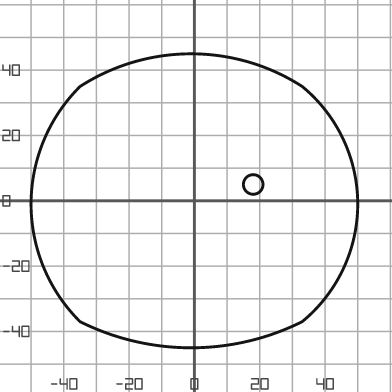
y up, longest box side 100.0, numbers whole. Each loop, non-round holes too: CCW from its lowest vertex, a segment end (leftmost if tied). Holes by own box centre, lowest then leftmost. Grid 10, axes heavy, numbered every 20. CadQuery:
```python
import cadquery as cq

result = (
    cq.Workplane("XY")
    .moveTo(-35.0, -37.0)
    .threePointArc((-1.0, -45.0), (33.0, -37.0))
    .threePointArc((50.0, -1.0), (33.0, 35.0))
    .threePointArc((-1.0, 45.0), (-35.0, 35.0))
    .threePointArc((-50.0, -1.0), (-35.0, -37.0))
    .close()
    .moveTo(18.0, 5.0)
    .circle(3.0)
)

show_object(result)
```